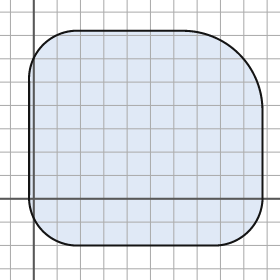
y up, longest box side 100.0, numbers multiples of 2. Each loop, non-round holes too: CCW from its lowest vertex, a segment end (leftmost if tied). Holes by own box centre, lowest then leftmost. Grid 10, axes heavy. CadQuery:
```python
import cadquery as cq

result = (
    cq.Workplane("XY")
    .moveTo(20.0, -20.0)
    .lineTo(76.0, -20.0)
    .threePointArc((92.0, -14.0), (98.0, 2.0))
    .lineTo(98.0, 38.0)
    .threePointArc((88.0, 62.0), (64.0, 72.0))
    .lineTo(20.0, 72.0)
    .threePointArc((4.0, 66.0), (-2.0, 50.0))
    .lineTo(-2.0, 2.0)
    .threePointArc((4.0, -14.0), (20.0, -20.0))
    .close()
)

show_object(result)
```